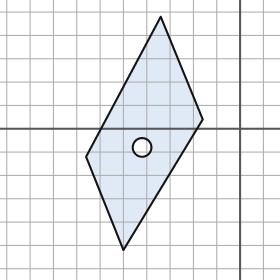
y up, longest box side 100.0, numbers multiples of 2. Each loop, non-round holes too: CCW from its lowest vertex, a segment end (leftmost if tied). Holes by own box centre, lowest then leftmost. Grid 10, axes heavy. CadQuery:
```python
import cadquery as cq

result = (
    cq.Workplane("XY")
    .moveTo(-50.0, -52.0)
    .lineTo(-16.0, 4.0)
    .lineTo(-34.0, 48.0)
    .lineTo(-66.0, -12.0)
    .close()
    .moveTo(-42.0, -8.0)
    .circle(4.0)
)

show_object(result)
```